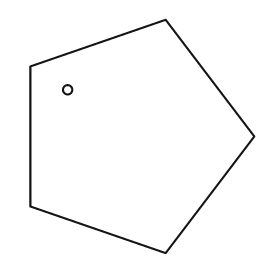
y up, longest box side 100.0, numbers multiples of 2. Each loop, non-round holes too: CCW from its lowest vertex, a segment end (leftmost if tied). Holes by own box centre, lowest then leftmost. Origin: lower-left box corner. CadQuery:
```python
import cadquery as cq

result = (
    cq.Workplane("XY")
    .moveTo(58.0, 0.0)
    .lineTo(96.0, 50.0)
    .lineTo(58.0, 100.0)
    .lineTo(0.0, 80.0)
    .lineTo(0.0, 20.0)
    .close()
    .moveTo(16.0, 70.0)
    .circle(2.0)
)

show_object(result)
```